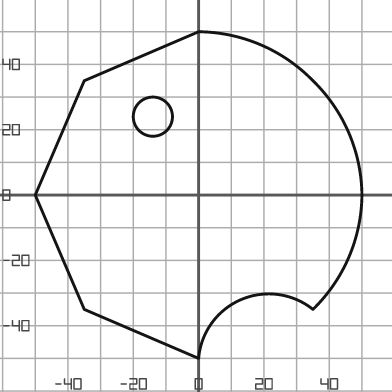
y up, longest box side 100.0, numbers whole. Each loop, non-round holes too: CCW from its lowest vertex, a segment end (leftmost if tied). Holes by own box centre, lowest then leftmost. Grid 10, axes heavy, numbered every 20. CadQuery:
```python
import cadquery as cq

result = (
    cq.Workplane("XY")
    .moveTo(0.0, -50.0)
    .threePointArc((13.0, -32.0), (35.0, -35.0))
    .threePointArc((46.0, -19.0), (50.0, 0.0))
    .threePointArc((46.0, 19.0), (35.0, 35.0))
    .threePointArc((19.0, 46.0), (0.0, 50.0))
    .lineTo(-35.0, 35.0)
    .lineTo(-50.0, 0.0)
    .lineTo(-35.0, -35.0)
    .close()
    .moveTo(-14.0, 24.0)
    .circle(6.0)
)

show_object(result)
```